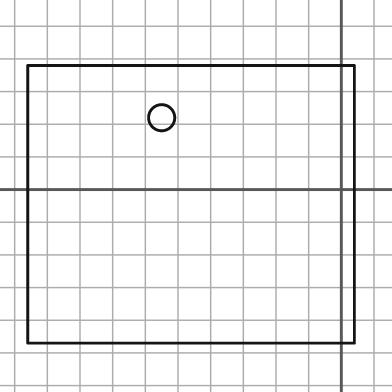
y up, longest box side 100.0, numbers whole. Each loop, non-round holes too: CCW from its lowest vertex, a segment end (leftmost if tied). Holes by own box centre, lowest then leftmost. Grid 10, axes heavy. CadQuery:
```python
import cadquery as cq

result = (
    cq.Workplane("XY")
    .moveTo(-96.0, -47.0)
    .lineTo(4.0, -47.0)
    .lineTo(4.0, 38.0)
    .lineTo(-96.0, 38.0)
    .close()
    .moveTo(-55.0, 22.0)
    .circle(4.0)
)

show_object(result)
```